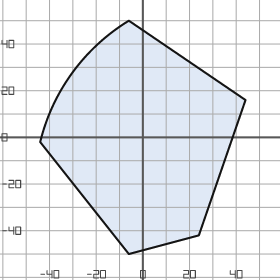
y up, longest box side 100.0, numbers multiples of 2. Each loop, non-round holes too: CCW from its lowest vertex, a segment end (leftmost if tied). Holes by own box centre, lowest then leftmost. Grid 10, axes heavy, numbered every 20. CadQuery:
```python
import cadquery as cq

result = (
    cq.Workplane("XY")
    .moveTo(-6.0, -50.0)
    .lineTo(24.0, -42.0)
    .lineTo(44.0, 16.0)
    .lineTo(-6.0, 50.0)
    .threePointArc((-30.0, 28.0), (-44.0, -2.0))
    .close()
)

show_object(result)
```